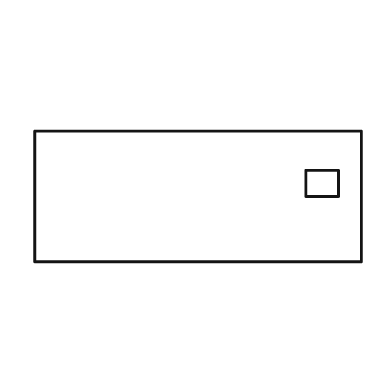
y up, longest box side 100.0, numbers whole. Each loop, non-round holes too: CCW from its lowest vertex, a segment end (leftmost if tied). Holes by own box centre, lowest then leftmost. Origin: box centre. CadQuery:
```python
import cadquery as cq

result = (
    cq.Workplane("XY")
    .moveTo(-50.0, -20.0)
    .lineTo(50.0, -20.0)
    .lineTo(50.0, 20.0)
    .lineTo(-50.0, 20.0)
    .close()
    .moveTo(33.0, 0.0)
    .lineTo(43.0, 0.0)
    .lineTo(43.0, 8.0)
    .lineTo(33.0, 8.0)
    .close()
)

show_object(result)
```